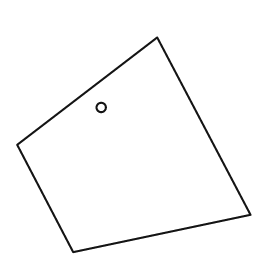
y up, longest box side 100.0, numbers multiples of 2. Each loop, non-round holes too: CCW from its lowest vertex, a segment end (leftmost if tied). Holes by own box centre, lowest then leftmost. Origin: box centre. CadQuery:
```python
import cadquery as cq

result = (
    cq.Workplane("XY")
    .moveTo(-26.0, -46.0)
    .lineTo(50.0, -30.0)
    .lineTo(10.0, 46.0)
    .lineTo(-50.0, 0.0)
    .close()
    .moveTo(-14.0, 16.0)
    .circle(2.0)
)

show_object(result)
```